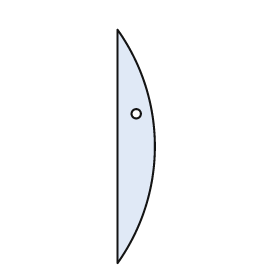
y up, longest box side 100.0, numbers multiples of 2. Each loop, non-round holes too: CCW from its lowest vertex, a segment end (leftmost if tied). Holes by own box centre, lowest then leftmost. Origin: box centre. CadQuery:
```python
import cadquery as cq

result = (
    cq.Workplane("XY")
    .moveTo(-8.0, -50.0)
    .threePointArc((8.0, 0.0), (-8.0, 50.0))
    .close()
    .moveTo(0.0, 14.0)
    .circle(2.0)
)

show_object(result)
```